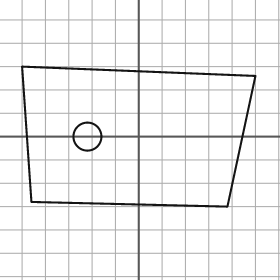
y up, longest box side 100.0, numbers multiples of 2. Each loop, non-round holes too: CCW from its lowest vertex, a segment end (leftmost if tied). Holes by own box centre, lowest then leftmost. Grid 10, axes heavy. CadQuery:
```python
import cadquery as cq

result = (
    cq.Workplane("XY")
    .moveTo(38.0, -30.0)
    .lineTo(50.0, 26.0)
    .lineTo(-50.0, 30.0)
    .lineTo(-46.0, -28.0)
    .close()
    .moveTo(-22.0, 0.0)
    .circle(6.0)
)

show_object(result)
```